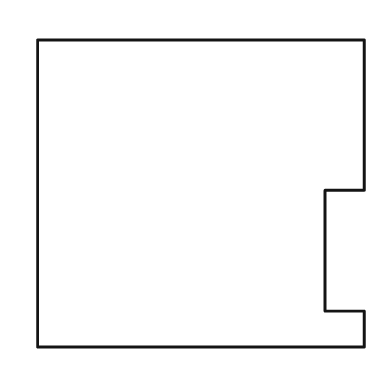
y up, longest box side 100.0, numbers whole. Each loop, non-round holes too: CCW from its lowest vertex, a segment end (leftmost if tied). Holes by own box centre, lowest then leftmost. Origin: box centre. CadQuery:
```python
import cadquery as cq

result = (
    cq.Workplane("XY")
    .moveTo(-50.0, -47.0)
    .lineTo(50.0, -47.0)
    .lineTo(50.0, -36.0)
    .lineTo(38.0, -36.0)
    .lineTo(38.0, 1.0)
    .lineTo(50.0, 1.0)
    .lineTo(50.0, 47.0)
    .lineTo(-50.0, 47.0)
    .close()
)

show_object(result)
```